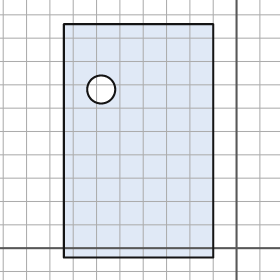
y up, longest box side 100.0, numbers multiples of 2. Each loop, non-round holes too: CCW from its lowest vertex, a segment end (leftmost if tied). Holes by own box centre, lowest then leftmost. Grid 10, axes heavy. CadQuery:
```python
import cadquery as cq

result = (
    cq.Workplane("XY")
    .moveTo(-74.0, -4.0)
    .lineTo(-10.0, -4.0)
    .lineTo(-10.0, 96.0)
    .lineTo(-74.0, 96.0)
    .close()
    .moveTo(-58.0, 68.0)
    .circle(6.0)
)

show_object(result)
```